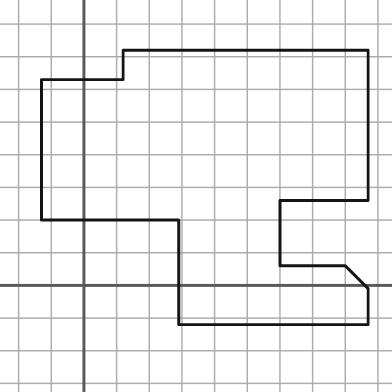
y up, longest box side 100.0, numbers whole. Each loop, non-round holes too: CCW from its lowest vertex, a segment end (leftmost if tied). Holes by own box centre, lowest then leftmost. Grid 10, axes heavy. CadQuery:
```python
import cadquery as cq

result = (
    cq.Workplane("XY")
    .moveTo(29.0, -12.0)
    .lineTo(87.0, -12.0)
    .lineTo(87.0, -1.0)
    .lineTo(80.0, 6.0)
    .lineTo(60.0, 6.0)
    .lineTo(60.0, 26.0)
    .lineTo(87.0, 26.0)
    .lineTo(87.0, 72.0)
    .lineTo(12.0, 72.0)
    .lineTo(12.0, 63.0)
    .lineTo(-13.0, 63.0)
    .lineTo(-13.0, 20.0)
    .lineTo(29.0, 20.0)
    .close()
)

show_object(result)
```